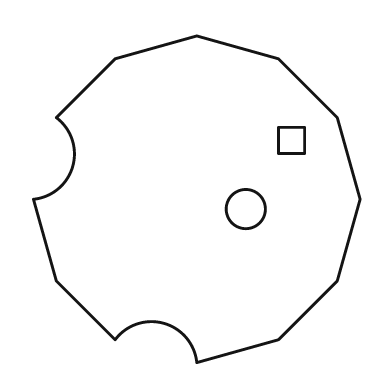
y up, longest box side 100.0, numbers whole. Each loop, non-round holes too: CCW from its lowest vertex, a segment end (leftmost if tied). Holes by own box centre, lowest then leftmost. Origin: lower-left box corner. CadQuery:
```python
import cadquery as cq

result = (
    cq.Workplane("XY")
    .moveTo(50.0, 0.0)
    .lineTo(75.0, 7.0)
    .lineTo(93.0, 25.0)
    .lineTo(100.0, 50.0)
    .lineTo(93.0, 75.0)
    .lineTo(75.0, 93.0)
    .lineTo(50.0, 100.0)
    .lineTo(25.0, 93.0)
    .lineTo(7.0, 75.0)
    .threePointArc((12.0, 60.0), (0.0, 50.0))
    .lineTo(7.0, 25.0)
    .lineTo(25.0, 7.0)
    .threePointArc((40.0, 12.0), (50.0, 0.0))
    .close()
    .moveTo(65.0, 47.0)
    .circle(6.0)
    .moveTo(75.0, 64.0)
    .lineTo(83.0, 64.0)
    .lineTo(83.0, 72.0)
    .lineTo(75.0, 72.0)
    .close()
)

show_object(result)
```